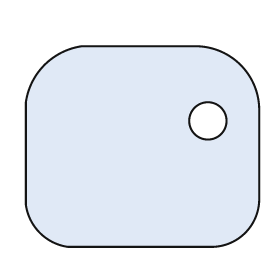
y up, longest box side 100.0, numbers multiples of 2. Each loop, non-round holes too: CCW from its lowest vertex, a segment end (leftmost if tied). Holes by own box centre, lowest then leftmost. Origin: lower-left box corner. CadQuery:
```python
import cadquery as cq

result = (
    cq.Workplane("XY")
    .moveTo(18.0, 0.0)
    .lineTo(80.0, 0.0)
    .threePointArc((94.0, 6.0), (100.0, 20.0))
    .lineTo(100.0, 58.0)
    .threePointArc((92.0, 78.0), (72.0, 86.0))
    .lineTo(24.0, 86.0)
    .threePointArc((8.0, 78.0), (0.0, 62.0))
    .lineTo(0.0, 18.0)
    .threePointArc((6.0, 6.0), (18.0, 0.0))
    .close()
    .moveTo(78.0, 54.0)
    .circle(8.0)
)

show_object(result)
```